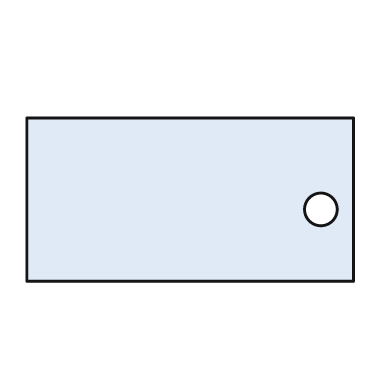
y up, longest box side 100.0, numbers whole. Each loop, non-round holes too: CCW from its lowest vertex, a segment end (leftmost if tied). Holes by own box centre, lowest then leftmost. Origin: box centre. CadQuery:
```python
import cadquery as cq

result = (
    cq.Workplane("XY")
    .moveTo(-50.0, -25.0)
    .lineTo(50.0, -25.0)
    .lineTo(50.0, 25.0)
    .lineTo(-50.0, 25.0)
    .close()
    .moveTo(40.0, -3.0)
    .circle(5.0)
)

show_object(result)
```